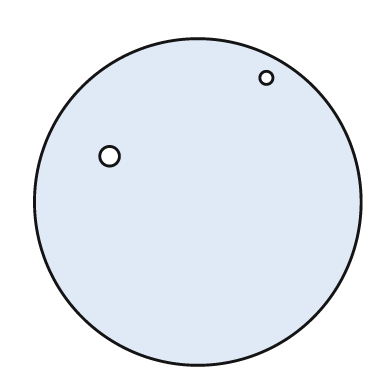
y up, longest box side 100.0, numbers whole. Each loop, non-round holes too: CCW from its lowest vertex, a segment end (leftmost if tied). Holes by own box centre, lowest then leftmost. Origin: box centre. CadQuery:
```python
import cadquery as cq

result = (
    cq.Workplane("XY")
    .moveTo(0.0, 0.0)
    .circle(50.0)
    .moveTo(-27.0, 14.0)
    .circle(3.0)
    .moveTo(21.0, 38.0)
    .circle(2.0)
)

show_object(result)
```